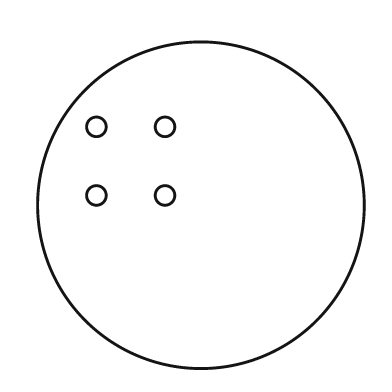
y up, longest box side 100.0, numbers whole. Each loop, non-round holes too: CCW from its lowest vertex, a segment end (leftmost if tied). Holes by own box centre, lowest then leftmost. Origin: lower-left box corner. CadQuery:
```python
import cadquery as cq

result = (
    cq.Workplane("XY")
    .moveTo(50.0, 50.0)
    .circle(50.0)
    .moveTo(18.0, 53.0)
    .circle(3.0)
    .moveTo(39.0, 53.0)
    .circle(3.0)
    .moveTo(18.0, 74.0)
    .circle(3.0)
    .moveTo(39.0, 74.0)
    .circle(3.0)
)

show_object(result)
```